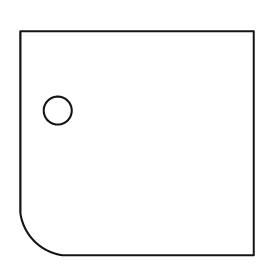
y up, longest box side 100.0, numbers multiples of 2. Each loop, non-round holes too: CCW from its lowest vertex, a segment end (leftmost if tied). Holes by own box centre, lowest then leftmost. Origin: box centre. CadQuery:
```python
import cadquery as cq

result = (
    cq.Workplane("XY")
    .moveTo(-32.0, -48.0)
    .lineTo(50.0, -48.0)
    .lineTo(50.0, 48.0)
    .lineTo(-50.0, 48.0)
    .lineTo(-50.0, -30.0)
    .threePointArc((-44.0, -42.0), (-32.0, -48.0))
    .close()
    .moveTo(-34.0, 14.0)
    .circle(6.0)
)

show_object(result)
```